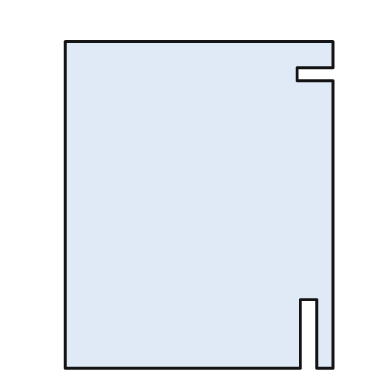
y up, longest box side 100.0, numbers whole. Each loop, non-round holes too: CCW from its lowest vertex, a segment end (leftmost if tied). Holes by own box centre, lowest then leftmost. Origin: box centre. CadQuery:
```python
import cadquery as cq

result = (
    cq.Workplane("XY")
    .moveTo(-41.0, -50.0)
    .lineTo(31.0, -50.0)
    .lineTo(31.0, -29.0)
    .lineTo(36.0, -29.0)
    .lineTo(36.0, -50.0)
    .lineTo(41.0, -50.0)
    .lineTo(41.0, 38.0)
    .lineTo(30.0, 38.0)
    .lineTo(30.0, 42.0)
    .lineTo(41.0, 42.0)
    .lineTo(41.0, 50.0)
    .lineTo(-41.0, 50.0)
    .close()
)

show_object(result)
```